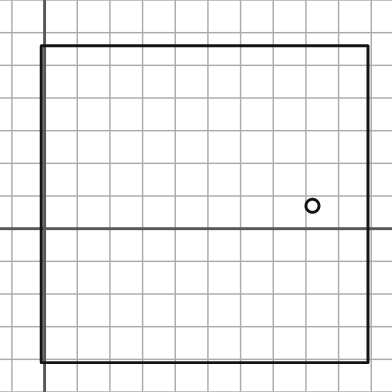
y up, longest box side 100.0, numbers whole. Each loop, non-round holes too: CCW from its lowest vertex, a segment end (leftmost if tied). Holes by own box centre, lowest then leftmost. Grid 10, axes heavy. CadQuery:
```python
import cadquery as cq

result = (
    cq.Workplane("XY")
    .moveTo(-1.0, -41.0)
    .lineTo(99.0, -41.0)
    .lineTo(99.0, 56.0)
    .lineTo(-1.0, 56.0)
    .close()
    .moveTo(82.0, 7.0)
    .circle(2.0)
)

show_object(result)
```